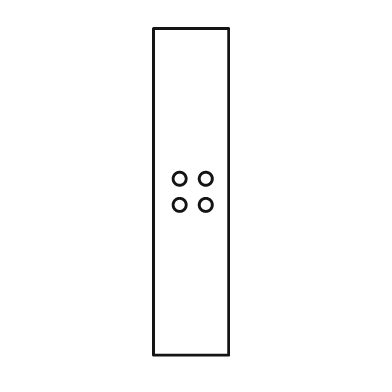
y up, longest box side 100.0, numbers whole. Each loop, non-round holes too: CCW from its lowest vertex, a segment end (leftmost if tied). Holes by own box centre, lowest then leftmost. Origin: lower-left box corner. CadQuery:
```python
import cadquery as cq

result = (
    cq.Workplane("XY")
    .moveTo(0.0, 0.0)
    .lineTo(23.0, 0.0)
    .lineTo(23.0, 100.0)
    .lineTo(0.0, 100.0)
    .close()
    .moveTo(8.0, 46.0)
    .circle(2.0)
    .moveTo(16.0, 46.0)
    .circle(2.0)
    .moveTo(8.0, 54.0)
    .circle(2.0)
    .moveTo(16.0, 54.0)
    .circle(2.0)
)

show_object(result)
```